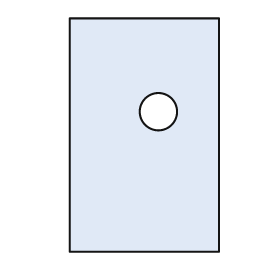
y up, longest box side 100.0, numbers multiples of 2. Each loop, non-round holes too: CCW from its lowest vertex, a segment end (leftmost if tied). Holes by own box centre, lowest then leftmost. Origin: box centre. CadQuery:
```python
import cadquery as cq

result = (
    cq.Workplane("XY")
    .moveTo(-32.0, -50.0)
    .lineTo(32.0, -50.0)
    .lineTo(32.0, 50.0)
    .lineTo(-32.0, 50.0)
    .close()
    .moveTo(6.0, 10.0)
    .circle(8.0)
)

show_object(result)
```